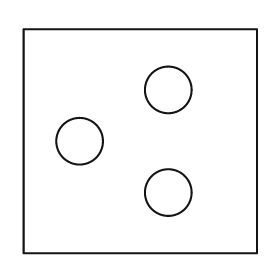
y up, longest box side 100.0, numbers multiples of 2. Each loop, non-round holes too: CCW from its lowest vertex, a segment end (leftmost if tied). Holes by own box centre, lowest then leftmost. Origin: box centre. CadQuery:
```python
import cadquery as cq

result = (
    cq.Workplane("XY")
    .moveTo(-50.0, -48.0)
    .lineTo(50.0, -48.0)
    .lineTo(50.0, 48.0)
    .lineTo(-50.0, 48.0)
    .close()
    .moveTo(12.0, -22.0)
    .circle(10.0)
    .moveTo(-26.0, 0.0)
    .circle(10.0)
    .moveTo(12.0, 22.0)
    .circle(10.0)
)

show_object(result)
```